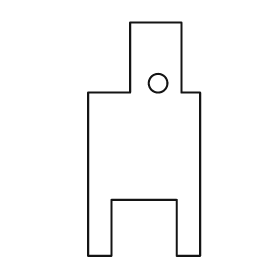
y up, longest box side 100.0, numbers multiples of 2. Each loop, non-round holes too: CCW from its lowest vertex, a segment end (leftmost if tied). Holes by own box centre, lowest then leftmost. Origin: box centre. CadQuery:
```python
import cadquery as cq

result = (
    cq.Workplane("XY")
    .moveTo(-24.0, -50.0)
    .lineTo(-14.0, -50.0)
    .lineTo(-14.0, -26.0)
    .lineTo(14.0, -26.0)
    .lineTo(14.0, -50.0)
    .lineTo(24.0, -50.0)
    .lineTo(24.0, 20.0)
    .lineTo(16.0, 20.0)
    .lineTo(16.0, 50.0)
    .lineTo(-6.0, 50.0)
    .lineTo(-6.0, 20.0)
    .lineTo(-24.0, 20.0)
    .close()
    .moveTo(6.0, 24.0)
    .circle(4.0)
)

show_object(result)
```